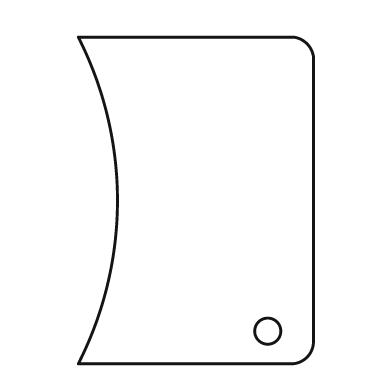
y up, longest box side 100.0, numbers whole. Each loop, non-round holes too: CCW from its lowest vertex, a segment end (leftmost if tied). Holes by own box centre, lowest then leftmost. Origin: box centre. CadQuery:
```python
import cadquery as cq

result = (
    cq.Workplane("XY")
    .moveTo(-36.0, -50.0)
    .lineTo(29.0, -50.0)
    .threePointArc((34.0, -48.0), (36.0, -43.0))
    .lineTo(36.0, 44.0)
    .threePointArc((34.0, 48.0), (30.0, 50.0))
    .lineTo(-36.0, 50.0)
    .threePointArc((-24.0, 0.0), (-36.0, -50.0))
    .close()
    .moveTo(22.0, -40.0)
    .circle(4.0)
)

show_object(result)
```